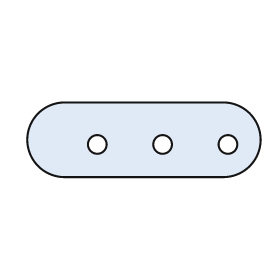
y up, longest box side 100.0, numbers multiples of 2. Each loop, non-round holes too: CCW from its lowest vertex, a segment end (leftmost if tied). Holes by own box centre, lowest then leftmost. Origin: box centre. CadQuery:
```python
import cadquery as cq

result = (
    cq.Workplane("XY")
    .moveTo(-34.0, -16.0)
    .lineTo(34.0, -16.0)
    .threePointArc((50.0, 0.0), (34.0, 16.0))
    .lineTo(-34.0, 16.0)
    .threePointArc((-50.0, 0.0), (-34.0, -16.0))
    .close()
    .moveTo(-20.0, -2.0)
    .circle(4.0)
    .moveTo(8.0, -2.0)
    .circle(4.0)
    .moveTo(36.0, -2.0)
    .circle(4.0)
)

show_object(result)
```